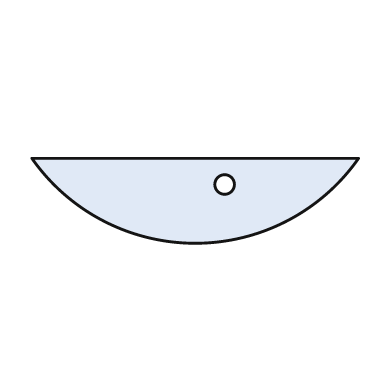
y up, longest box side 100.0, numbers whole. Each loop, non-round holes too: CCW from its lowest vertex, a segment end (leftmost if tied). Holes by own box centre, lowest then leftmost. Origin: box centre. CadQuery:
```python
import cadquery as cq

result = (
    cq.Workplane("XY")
    .moveTo(-50.0, 13.0)
    .threePointArc((0.0, -13.0), (50.0, 13.0))
    .close()
    .moveTo(9.0, 5.0)
    .circle(3.0)
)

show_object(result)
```